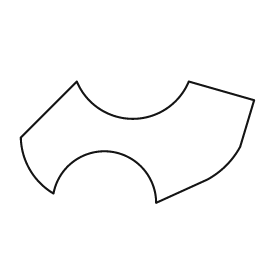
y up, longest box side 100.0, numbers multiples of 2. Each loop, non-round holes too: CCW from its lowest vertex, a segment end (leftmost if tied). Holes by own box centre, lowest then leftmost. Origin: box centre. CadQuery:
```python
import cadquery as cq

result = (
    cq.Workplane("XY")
    .moveTo(8.0, -26.0)
    .lineTo(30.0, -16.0)
    .threePointArc((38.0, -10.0), (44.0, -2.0))
    .lineTo(50.0, 18.0)
    .lineTo(22.0, 26.0)
    .threePointArc((-2.0, 10.0), (-26.0, 26.0))
    .lineTo(-50.0, 2.0)
    .threePointArc((-46.0, -12.0), (-36.0, -22.0))
    .threePointArc((-12.0, -4.0), (8.0, -26.0))
    .close()
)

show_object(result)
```